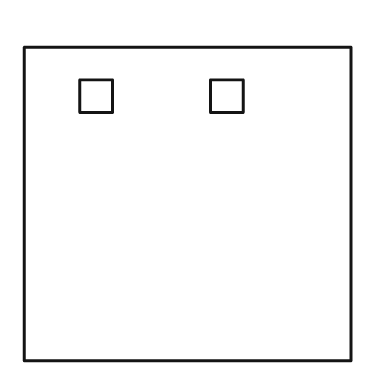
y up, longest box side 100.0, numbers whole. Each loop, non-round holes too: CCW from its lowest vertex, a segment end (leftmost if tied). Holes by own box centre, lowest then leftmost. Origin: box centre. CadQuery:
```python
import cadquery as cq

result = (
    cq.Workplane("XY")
    .moveTo(-50.0, -48.0)
    .lineTo(50.0, -48.0)
    .lineTo(50.0, 48.0)
    .lineTo(-50.0, 48.0)
    .close()
    .moveTo(-33.0, 28.0)
    .lineTo(-23.0, 28.0)
    .lineTo(-23.0, 38.0)
    .lineTo(-33.0, 38.0)
    .close()
    .moveTo(7.0, 28.0)
    .lineTo(17.0, 28.0)
    .lineTo(17.0, 38.0)
    .lineTo(7.0, 38.0)
    .close()
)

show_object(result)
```